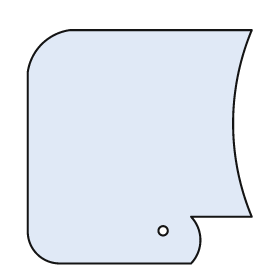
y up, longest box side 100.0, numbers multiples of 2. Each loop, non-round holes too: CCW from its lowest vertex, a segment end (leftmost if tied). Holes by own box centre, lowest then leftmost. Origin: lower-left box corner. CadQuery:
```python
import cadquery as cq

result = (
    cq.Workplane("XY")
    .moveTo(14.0, 0.0)
    .lineTo(70.0, 0.0)
    .threePointArc((74.0, 10.0), (70.0, 20.0))
    .lineTo(96.0, 20.0)
    .threePointArc((88.0, 60.0), (96.0, 100.0))
    .lineTo(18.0, 100.0)
    .threePointArc((6.0, 94.0), (0.0, 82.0))
    .lineTo(0.0, 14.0)
    .threePointArc((4.0, 4.0), (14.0, 0.0))
    .close()
    .moveTo(58.0, 14.0)
    .circle(2.0)
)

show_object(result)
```